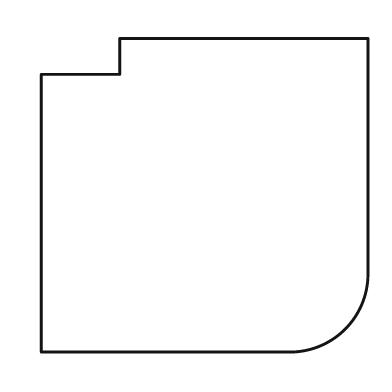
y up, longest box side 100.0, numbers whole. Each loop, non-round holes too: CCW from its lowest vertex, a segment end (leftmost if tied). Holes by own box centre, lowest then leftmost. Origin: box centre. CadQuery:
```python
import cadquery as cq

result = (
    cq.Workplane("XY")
    .moveTo(-50.0, -48.0)
    .lineTo(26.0, -48.0)
    .threePointArc((43.0, -41.0), (50.0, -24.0))
    .lineTo(50.0, 48.0)
    .lineTo(-26.0, 48.0)
    .lineTo(-26.0, 37.0)
    .lineTo(-50.0, 37.0)
    .close()
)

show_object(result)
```